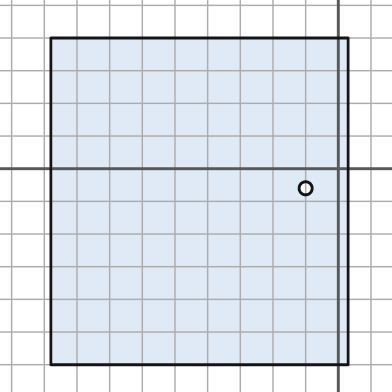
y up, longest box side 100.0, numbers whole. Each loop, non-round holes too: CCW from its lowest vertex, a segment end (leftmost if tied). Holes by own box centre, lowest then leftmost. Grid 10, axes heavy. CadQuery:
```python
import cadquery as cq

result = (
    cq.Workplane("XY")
    .moveTo(-88.0, -60.0)
    .lineTo(3.0, -60.0)
    .lineTo(3.0, 40.0)
    .lineTo(-88.0, 40.0)
    .close()
    .moveTo(-10.0, -6.0)
    .circle(2.0)
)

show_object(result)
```